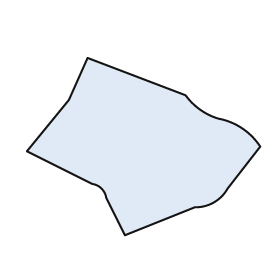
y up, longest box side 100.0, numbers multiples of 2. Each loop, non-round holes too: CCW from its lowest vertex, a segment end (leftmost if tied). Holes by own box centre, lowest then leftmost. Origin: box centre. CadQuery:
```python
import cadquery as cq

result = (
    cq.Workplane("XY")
    .moveTo(-8.0, -38.0)
    .lineTo(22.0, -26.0)
    .threePointArc((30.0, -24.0), (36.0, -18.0))
    .lineTo(50.0, 0.0)
    .threePointArc((42.0, 8.0), (32.0, 12.0))
    .threePointArc((24.0, 16.0), (18.0, 22.0))
    .lineTo(-24.0, 38.0)
    .lineTo(-32.0, 20.0)
    .lineTo(-50.0, -2.0)
    .lineTo(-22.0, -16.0)
    .threePointArc((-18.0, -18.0), (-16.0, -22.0))
    .close()
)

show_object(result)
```